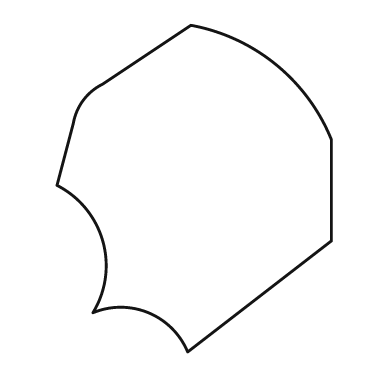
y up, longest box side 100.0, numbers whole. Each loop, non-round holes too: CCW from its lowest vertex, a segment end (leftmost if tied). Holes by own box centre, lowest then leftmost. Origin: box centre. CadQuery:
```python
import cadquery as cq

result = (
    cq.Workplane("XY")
    .moveTo(-2.0, -50.0)
    .lineTo(42.0, -16.0)
    .lineTo(42.0, 15.0)
    .threePointArc((25.0, 38.0), (-1.0, 50.0))
    .lineTo(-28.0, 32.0)
    .threePointArc((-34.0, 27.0), (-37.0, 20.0))
    .lineTo(-42.0, 1.0)
    .threePointArc((-28.0, -16.0), (-31.0, -38.0))
    .threePointArc((-14.0, -38.0), (-2.0, -50.0))
    .close()
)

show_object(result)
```